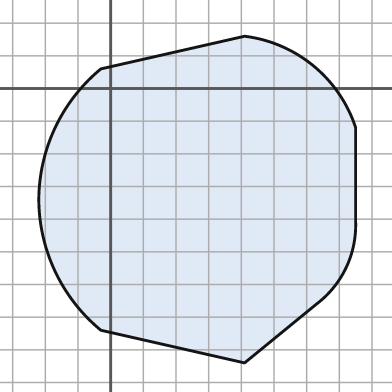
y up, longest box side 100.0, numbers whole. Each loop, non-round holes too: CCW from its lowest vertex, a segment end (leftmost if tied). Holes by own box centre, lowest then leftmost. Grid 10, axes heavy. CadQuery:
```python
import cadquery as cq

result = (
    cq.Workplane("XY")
    .moveTo(41.0, -84.0)
    .lineTo(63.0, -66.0)
    .threePointArc((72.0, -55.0), (75.0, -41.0))
    .lineTo(75.0, -12.0)
    .threePointArc((62.0, 7.0), (41.0, 16.0))
    .lineTo(-3.0, 6.0)
    .threePointArc((-17.0, -12.0), (-22.0, -34.0))
    .threePointArc((-17.0, -56.0), (-3.0, -74.0))
    .close()
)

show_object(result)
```